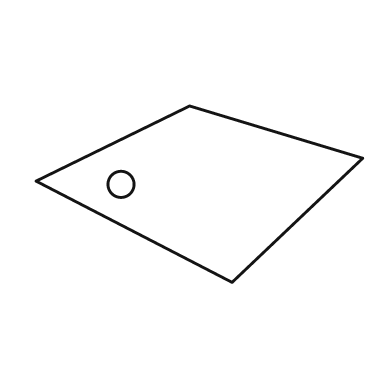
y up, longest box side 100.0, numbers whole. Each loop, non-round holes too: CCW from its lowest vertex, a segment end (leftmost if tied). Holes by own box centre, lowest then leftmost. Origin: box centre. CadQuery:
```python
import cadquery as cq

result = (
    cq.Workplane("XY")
    .moveTo(10.0, -27.0)
    .lineTo(50.0, 11.0)
    .lineTo(-3.0, 27.0)
    .lineTo(-50.0, 4.0)
    .close()
    .moveTo(-24.0, 3.0)
    .circle(4.0)
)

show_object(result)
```